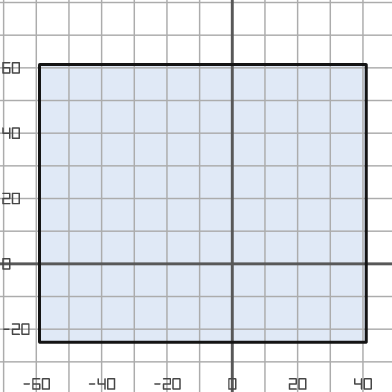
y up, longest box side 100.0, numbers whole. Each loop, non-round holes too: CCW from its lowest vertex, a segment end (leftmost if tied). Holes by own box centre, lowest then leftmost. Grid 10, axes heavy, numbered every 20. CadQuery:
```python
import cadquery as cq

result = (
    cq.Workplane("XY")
    .moveTo(-59.0, -24.0)
    .lineTo(41.0, -24.0)
    .lineTo(41.0, 61.0)
    .lineTo(-59.0, 61.0)
    .close()
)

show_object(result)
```